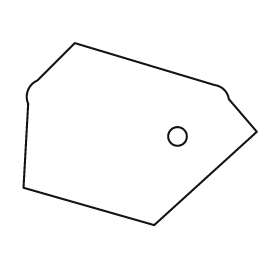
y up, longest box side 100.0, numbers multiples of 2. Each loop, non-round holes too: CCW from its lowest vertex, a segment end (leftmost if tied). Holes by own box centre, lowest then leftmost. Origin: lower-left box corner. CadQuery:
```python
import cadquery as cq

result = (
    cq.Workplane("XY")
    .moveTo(56.0, 0.0)
    .lineTo(100.0, 40.0)
    .lineTo(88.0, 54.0)
    .threePointArc((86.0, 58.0), (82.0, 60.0))
    .lineTo(22.0, 78.0)
    .lineTo(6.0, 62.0)
    .threePointArc((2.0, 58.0), (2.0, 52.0))
    .lineTo(0.0, 16.0)
    .close()
    .moveTo(66.0, 38.0)
    .circle(4.0)
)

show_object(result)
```